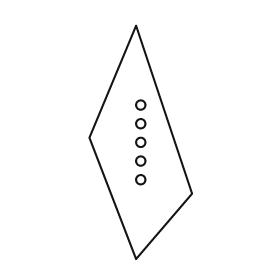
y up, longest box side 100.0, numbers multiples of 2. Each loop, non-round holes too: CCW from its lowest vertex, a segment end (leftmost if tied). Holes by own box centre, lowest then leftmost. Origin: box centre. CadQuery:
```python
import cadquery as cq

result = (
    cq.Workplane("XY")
    .moveTo(-2.0, -50.0)
    .lineTo(22.0, -22.0)
    .lineTo(-2.0, 50.0)
    .lineTo(-22.0, 2.0)
    .close()
    .moveTo(0.0, -16.0)
    .circle(2.0)
    .moveTo(0.0, -8.0)
    .circle(2.0)
    .moveTo(0.0, 0.0)
    .circle(2.0)
    .moveTo(0.0, 8.0)
    .circle(2.0)
    .moveTo(0.0, 16.0)
    .circle(2.0)
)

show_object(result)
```